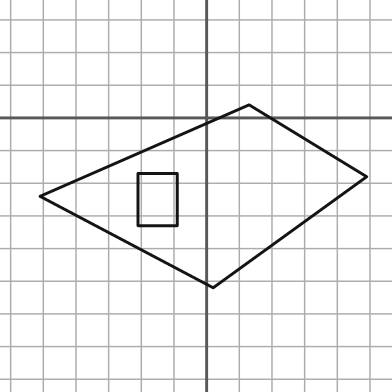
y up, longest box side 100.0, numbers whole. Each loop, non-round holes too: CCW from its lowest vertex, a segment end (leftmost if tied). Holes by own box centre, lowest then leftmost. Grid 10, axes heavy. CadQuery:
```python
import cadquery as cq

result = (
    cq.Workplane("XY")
    .moveTo(2.0, -52.0)
    .lineTo(49.0, -18.0)
    .lineTo(13.0, 4.0)
    .lineTo(-51.0, -24.0)
    .close()
    .moveTo(-21.0, -33.0)
    .lineTo(-9.0, -33.0)
    .lineTo(-9.0, -17.0)
    .lineTo(-21.0, -17.0)
    .close()
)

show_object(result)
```